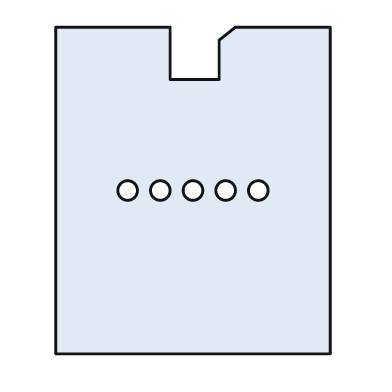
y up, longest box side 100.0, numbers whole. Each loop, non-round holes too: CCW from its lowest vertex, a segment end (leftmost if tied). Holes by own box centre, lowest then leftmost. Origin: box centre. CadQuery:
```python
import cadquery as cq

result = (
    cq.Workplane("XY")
    .moveTo(-42.0, -50.0)
    .lineTo(42.0, -50.0)
    .lineTo(42.0, 50.0)
    .lineTo(13.0, 50.0)
    .lineTo(8.0, 46.0)
    .lineTo(8.0, 34.0)
    .lineTo(-7.0, 34.0)
    .lineTo(-7.0, 50.0)
    .lineTo(-42.0, 50.0)
    .close()
    .moveTo(-20.0, 0.0)
    .circle(3.0)
    .moveTo(-10.0, 0.0)
    .circle(3.0)
    .moveTo(0.0, 0.0)
    .circle(3.0)
    .moveTo(10.0, 0.0)
    .circle(3.0)
    .moveTo(20.0, 0.0)
    .circle(3.0)
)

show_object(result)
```